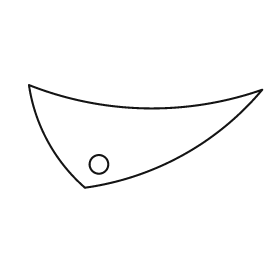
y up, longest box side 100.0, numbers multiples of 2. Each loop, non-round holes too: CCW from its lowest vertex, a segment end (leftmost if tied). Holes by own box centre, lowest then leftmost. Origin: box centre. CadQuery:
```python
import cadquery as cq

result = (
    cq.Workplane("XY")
    .moveTo(-26.0, -22.0)
    .threePointArc((16.0, -8.0), (50.0, 20.0))
    .threePointArc((0.0, 12.0), (-50.0, 22.0))
    .threePointArc((-42.0, -2.0), (-26.0, -22.0))
    .close()
    .moveTo(-20.0, -12.0)
    .circle(4.0)
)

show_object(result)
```